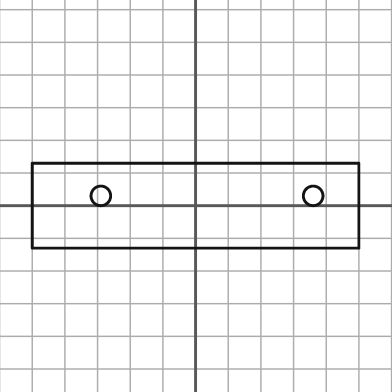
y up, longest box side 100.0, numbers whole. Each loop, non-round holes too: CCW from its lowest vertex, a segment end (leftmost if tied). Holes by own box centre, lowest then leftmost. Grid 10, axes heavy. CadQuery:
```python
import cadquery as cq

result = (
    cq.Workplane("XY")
    .moveTo(-50.0, -13.0)
    .lineTo(50.0, -13.0)
    .lineTo(50.0, 13.0)
    .lineTo(-50.0, 13.0)
    .close()
    .moveTo(-29.0, 3.0)
    .circle(3.0)
    .moveTo(36.0, 3.0)
    .circle(3.0)
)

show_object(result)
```